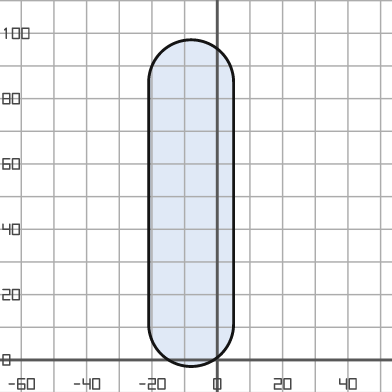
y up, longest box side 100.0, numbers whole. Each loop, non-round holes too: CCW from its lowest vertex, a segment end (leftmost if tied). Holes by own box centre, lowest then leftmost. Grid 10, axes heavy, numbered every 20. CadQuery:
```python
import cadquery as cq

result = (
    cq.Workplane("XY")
    .moveTo(-21.0, 11.0)
    .threePointArc((-8.0, -2.0), (5.0, 11.0))
    .lineTo(5.0, 85.0)
    .threePointArc((-8.0, 98.0), (-21.0, 85.0))
    .close()
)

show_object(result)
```